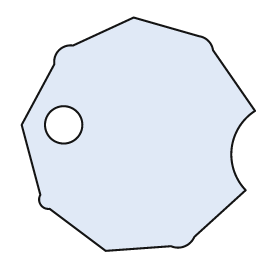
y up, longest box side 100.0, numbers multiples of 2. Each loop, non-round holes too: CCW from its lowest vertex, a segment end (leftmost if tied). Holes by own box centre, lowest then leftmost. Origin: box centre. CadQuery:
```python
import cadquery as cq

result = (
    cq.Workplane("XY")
    .moveTo(-14.0, -50.0)
    .lineTo(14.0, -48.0)
    .threePointArc((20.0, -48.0), (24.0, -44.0))
    .lineTo(46.0, -24.0)
    .threePointArc((40.0, -6.0), (50.0, 10.0))
    .lineTo(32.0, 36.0)
    .threePointArc((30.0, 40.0), (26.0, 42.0))
    .lineTo(-2.0, 50.0)
    .lineTo(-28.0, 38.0)
    .threePointArc((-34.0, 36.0), (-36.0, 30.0))
    .lineTo(-50.0, 4.0)
    .lineTo(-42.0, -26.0)
    .threePointArc((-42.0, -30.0), (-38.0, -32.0))
    .close()
    .moveTo(-32.0, 4.0)
    .circle(8.0)
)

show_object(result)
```